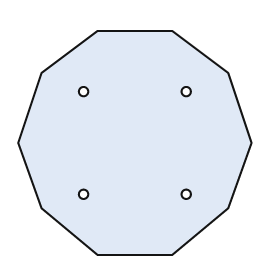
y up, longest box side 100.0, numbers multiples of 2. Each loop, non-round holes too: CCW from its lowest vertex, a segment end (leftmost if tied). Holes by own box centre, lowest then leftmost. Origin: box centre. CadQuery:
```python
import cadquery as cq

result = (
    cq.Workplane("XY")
    .moveTo(-16.0, -48.0)
    .lineTo(16.0, -48.0)
    .lineTo(40.0, -28.0)
    .lineTo(50.0, 0.0)
    .lineTo(40.0, 30.0)
    .lineTo(16.0, 48.0)
    .lineTo(-16.0, 48.0)
    .lineTo(-40.0, 30.0)
    .lineTo(-50.0, 0.0)
    .lineTo(-40.0, -28.0)
    .close()
    .moveTo(-22.0, -22.0)
    .circle(2.0)
    .moveTo(22.0, -22.0)
    .circle(2.0)
    .moveTo(-22.0, 22.0)
    .circle(2.0)
    .moveTo(22.0, 22.0)
    .circle(2.0)
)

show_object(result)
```